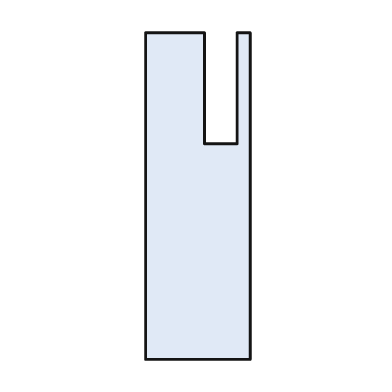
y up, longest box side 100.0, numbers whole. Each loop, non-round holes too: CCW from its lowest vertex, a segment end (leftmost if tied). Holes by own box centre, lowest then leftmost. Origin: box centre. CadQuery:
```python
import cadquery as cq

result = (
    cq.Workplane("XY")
    .moveTo(-16.0, -50.0)
    .lineTo(16.0, -50.0)
    .lineTo(16.0, 50.0)
    .lineTo(12.0, 50.0)
    .lineTo(12.0, 16.0)
    .lineTo(2.0, 16.0)
    .lineTo(2.0, 50.0)
    .lineTo(-16.0, 50.0)
    .close()
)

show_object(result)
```